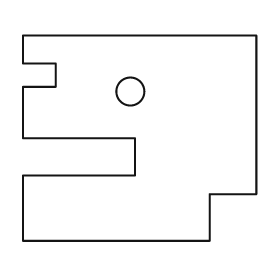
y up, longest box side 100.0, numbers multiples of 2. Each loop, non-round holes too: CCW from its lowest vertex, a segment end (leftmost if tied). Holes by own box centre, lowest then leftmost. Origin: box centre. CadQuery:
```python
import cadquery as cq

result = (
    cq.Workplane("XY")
    .moveTo(-50.0, -44.0)
    .lineTo(30.0, -44.0)
    .lineTo(30.0, -24.0)
    .lineTo(50.0, -24.0)
    .lineTo(50.0, 44.0)
    .lineTo(-50.0, 44.0)
    .lineTo(-50.0, 32.0)
    .lineTo(-36.0, 32.0)
    .lineTo(-36.0, 22.0)
    .lineTo(-50.0, 22.0)
    .lineTo(-50.0, 0.0)
    .lineTo(-2.0, 0.0)
    .lineTo(-2.0, -16.0)
    .lineTo(-50.0, -16.0)
    .close()
    .moveTo(-4.0, 20.0)
    .circle(6.0)
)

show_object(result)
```